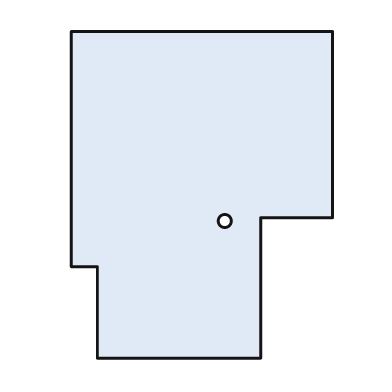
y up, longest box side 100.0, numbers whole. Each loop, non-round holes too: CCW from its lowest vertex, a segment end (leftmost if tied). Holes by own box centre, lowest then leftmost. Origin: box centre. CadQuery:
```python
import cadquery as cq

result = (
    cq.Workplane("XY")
    .moveTo(-32.0, -50.0)
    .lineTo(18.0, -50.0)
    .lineTo(18.0, -7.0)
    .lineTo(40.0, -7.0)
    .lineTo(40.0, 50.0)
    .lineTo(-40.0, 50.0)
    .lineTo(-40.0, -22.0)
    .lineTo(-32.0, -22.0)
    .close()
    .moveTo(7.0, -8.0)
    .circle(2.0)
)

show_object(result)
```